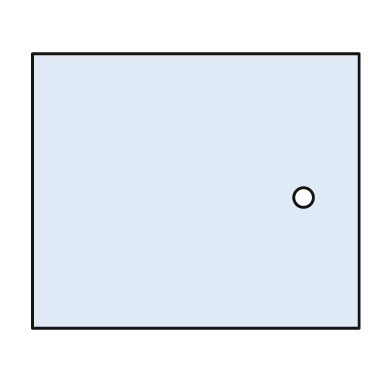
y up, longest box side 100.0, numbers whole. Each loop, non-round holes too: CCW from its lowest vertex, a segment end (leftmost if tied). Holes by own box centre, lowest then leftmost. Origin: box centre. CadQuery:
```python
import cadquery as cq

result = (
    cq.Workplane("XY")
    .moveTo(-50.0, -42.0)
    .lineTo(50.0, -42.0)
    .lineTo(50.0, 42.0)
    .lineTo(-50.0, 42.0)
    .close()
    .moveTo(33.0, -2.0)
    .circle(3.0)
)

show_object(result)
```